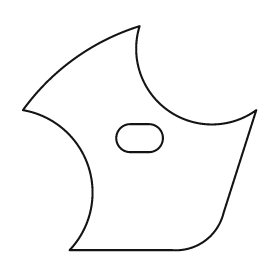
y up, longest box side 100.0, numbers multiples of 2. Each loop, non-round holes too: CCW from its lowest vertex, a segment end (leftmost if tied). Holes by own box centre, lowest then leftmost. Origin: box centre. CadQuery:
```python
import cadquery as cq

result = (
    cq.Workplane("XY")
    .moveTo(-30.0, -48.0)
    .lineTo(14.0, -48.0)
    .threePointArc((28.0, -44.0), (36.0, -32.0))
    .lineTo(50.0, 12.0)
    .threePointArc((12.0, 12.0), (0.0, 48.0))
    .threePointArc((-28.0, 34.0), (-50.0, 12.0))
    .threePointArc((-22.0, -12.0), (-30.0, -48.0))
    .close()
    .moveTo(-4.0, -6.0)
    .lineTo(4.0, -6.0)
    .threePointArc((10.0, 0.0), (4.0, 6.0))
    .lineTo(-4.0, 6.0)
    .threePointArc((-10.0, 0.0), (-4.0, -6.0))
    .close()
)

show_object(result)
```